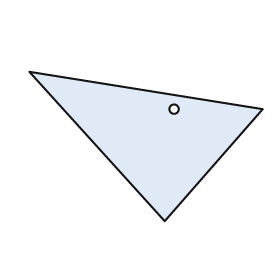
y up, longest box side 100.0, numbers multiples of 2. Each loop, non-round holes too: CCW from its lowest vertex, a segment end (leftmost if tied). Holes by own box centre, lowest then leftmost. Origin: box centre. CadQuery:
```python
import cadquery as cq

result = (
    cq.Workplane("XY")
    .moveTo(8.0, -32.0)
    .lineTo(50.0, 16.0)
    .lineTo(-50.0, 32.0)
    .close()
    .moveTo(12.0, 16.0)
    .circle(2.0)
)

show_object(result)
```